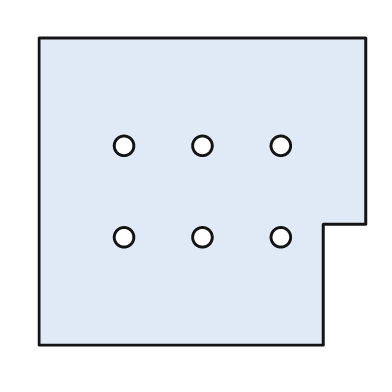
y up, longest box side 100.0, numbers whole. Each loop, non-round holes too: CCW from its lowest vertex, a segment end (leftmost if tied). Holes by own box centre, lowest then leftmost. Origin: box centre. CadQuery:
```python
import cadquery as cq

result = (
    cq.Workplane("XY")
    .moveTo(-50.0, -47.0)
    .lineTo(37.0, -47.0)
    .lineTo(37.0, -10.0)
    .lineTo(50.0, -10.0)
    .lineTo(50.0, 47.0)
    .lineTo(-50.0, 47.0)
    .close()
    .moveTo(-24.0, -14.0)
    .circle(3.0)
    .moveTo(0.0, -14.0)
    .circle(3.0)
    .moveTo(24.0, -14.0)
    .circle(3.0)
    .moveTo(-24.0, 14.0)
    .circle(3.0)
    .moveTo(0.0, 14.0)
    .circle(3.0)
    .moveTo(24.0, 14.0)
    .circle(3.0)
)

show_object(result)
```